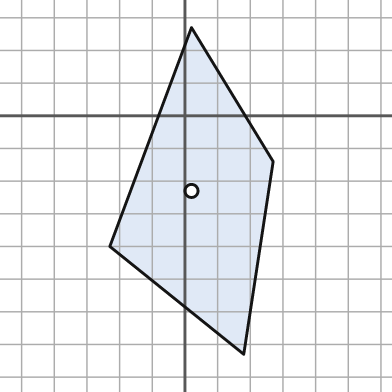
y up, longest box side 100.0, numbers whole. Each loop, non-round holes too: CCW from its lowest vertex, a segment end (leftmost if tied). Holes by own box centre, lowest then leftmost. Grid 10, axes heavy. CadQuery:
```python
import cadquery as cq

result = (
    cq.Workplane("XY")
    .moveTo(18.0, -73.0)
    .lineTo(27.0, -14.0)
    .lineTo(2.0, 27.0)
    .lineTo(-23.0, -40.0)
    .close()
    .moveTo(2.0, -23.0)
    .circle(2.0)
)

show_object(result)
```